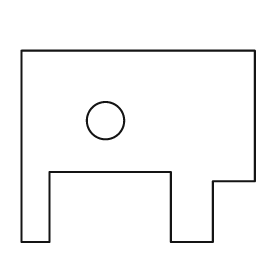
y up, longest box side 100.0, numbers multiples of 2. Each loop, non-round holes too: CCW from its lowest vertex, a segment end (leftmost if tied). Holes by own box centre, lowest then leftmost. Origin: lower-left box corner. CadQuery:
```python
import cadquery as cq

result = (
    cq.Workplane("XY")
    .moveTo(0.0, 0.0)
    .lineTo(12.0, 0.0)
    .lineTo(12.0, 30.0)
    .lineTo(64.0, 30.0)
    .lineTo(64.0, 0.0)
    .lineTo(82.0, 0.0)
    .lineTo(82.0, 26.0)
    .lineTo(100.0, 26.0)
    .lineTo(100.0, 82.0)
    .lineTo(0.0, 82.0)
    .close()
    .moveTo(36.0, 52.0)
    .circle(8.0)
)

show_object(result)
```